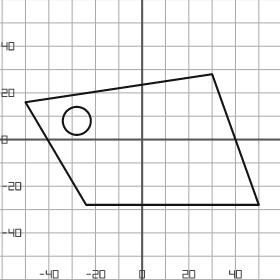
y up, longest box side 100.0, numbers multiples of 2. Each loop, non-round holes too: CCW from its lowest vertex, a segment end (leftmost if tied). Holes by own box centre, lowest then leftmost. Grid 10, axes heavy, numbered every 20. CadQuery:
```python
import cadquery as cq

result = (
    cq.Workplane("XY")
    .moveTo(-24.0, -28.0)
    .lineTo(50.0, -28.0)
    .lineTo(30.0, 28.0)
    .lineTo(-50.0, 16.0)
    .close()
    .moveTo(-28.0, 8.0)
    .circle(6.0)
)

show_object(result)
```